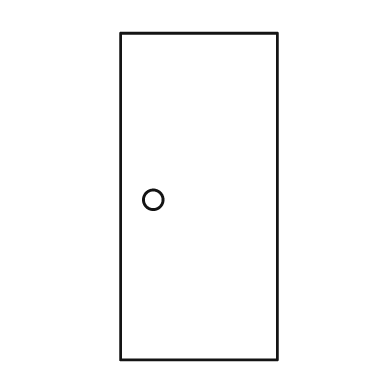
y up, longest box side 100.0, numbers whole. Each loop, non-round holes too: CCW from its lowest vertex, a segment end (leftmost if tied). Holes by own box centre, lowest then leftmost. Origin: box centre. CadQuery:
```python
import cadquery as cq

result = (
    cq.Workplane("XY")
    .moveTo(-24.0, -50.0)
    .lineTo(24.0, -50.0)
    .lineTo(24.0, 50.0)
    .lineTo(-24.0, 50.0)
    .close()
    .moveTo(-14.0, -1.0)
    .circle(3.0)
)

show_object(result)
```